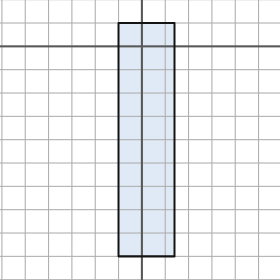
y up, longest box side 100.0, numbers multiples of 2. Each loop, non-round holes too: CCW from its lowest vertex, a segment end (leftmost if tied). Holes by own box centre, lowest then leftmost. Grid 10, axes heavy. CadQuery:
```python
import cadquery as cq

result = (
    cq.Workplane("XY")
    .moveTo(-10.0, -90.0)
    .lineTo(14.0, -90.0)
    .lineTo(14.0, 10.0)
    .lineTo(-10.0, 10.0)
    .close()
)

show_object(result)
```